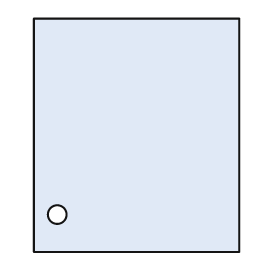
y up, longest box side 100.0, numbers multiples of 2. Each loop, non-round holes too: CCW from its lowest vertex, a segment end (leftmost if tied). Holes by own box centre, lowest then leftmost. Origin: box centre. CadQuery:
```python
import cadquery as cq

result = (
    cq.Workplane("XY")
    .moveTo(-44.0, -50.0)
    .lineTo(44.0, -50.0)
    .lineTo(44.0, 50.0)
    .lineTo(-44.0, 50.0)
    .close()
    .moveTo(-34.0, -34.0)
    .circle(4.0)
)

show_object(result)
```